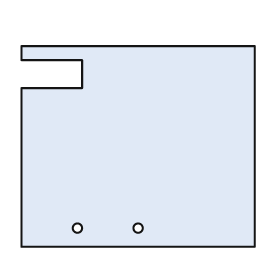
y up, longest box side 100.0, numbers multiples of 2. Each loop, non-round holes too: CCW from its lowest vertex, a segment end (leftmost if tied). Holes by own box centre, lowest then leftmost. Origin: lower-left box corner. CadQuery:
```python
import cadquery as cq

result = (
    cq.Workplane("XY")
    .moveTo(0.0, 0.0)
    .lineTo(100.0, 0.0)
    .lineTo(100.0, 86.0)
    .lineTo(0.0, 86.0)
    .lineTo(0.0, 80.0)
    .lineTo(26.0, 80.0)
    .lineTo(26.0, 68.0)
    .lineTo(0.0, 68.0)
    .close()
    .moveTo(24.0, 8.0)
    .circle(2.0)
    .moveTo(50.0, 8.0)
    .circle(2.0)
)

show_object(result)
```